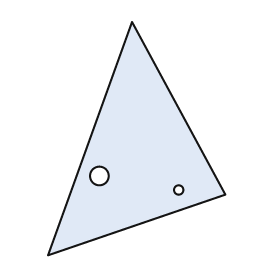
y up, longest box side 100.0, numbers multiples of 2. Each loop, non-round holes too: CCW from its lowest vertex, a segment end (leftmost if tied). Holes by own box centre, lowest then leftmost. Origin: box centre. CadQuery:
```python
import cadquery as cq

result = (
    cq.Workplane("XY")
    .moveTo(-38.0, -50.0)
    .lineTo(38.0, -24.0)
    .lineTo(-2.0, 50.0)
    .close()
    .moveTo(18.0, -22.0)
    .circle(2.0)
    .moveTo(-16.0, -16.0)
    .circle(4.0)
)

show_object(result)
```